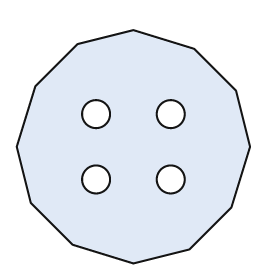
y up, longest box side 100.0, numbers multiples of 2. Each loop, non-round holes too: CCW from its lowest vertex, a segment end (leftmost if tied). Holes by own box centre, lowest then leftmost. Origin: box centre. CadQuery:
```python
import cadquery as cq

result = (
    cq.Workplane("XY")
    .moveTo(0.0, -50.0)
    .lineTo(24.0, -44.0)
    .lineTo(42.0, -26.0)
    .lineTo(50.0, 0.0)
    .lineTo(44.0, 24.0)
    .lineTo(26.0, 42.0)
    .lineTo(0.0, 50.0)
    .lineTo(-24.0, 44.0)
    .lineTo(-42.0, 26.0)
    .lineTo(-50.0, 0.0)
    .lineTo(-44.0, -24.0)
    .lineTo(-26.0, -42.0)
    .close()
    .moveTo(-16.0, -14.0)
    .circle(6.0)
    .moveTo(16.0, -14.0)
    .circle(6.0)
    .moveTo(-16.0, 14.0)
    .circle(6.0)
    .moveTo(16.0, 14.0)
    .circle(6.0)
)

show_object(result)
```